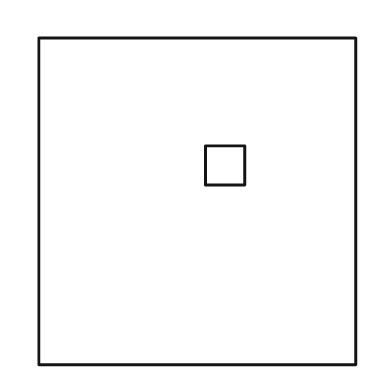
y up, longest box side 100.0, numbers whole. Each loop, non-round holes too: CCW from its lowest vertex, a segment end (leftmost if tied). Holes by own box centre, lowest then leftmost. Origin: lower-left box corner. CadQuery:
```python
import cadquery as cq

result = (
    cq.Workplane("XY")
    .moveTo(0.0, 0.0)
    .lineTo(97.0, 0.0)
    .lineTo(97.0, 100.0)
    .lineTo(0.0, 100.0)
    .close()
    .moveTo(51.0, 55.0)
    .lineTo(63.0, 55.0)
    .lineTo(63.0, 67.0)
    .lineTo(51.0, 67.0)
    .close()
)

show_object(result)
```